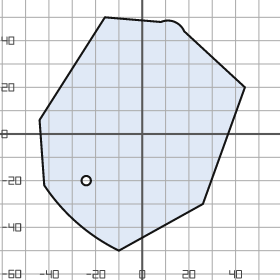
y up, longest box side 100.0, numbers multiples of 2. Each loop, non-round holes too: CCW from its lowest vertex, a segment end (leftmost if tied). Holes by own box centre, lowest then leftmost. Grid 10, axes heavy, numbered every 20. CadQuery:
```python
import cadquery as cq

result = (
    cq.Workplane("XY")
    .moveTo(-10.0, -50.0)
    .lineTo(26.0, -30.0)
    .lineTo(44.0, 20.0)
    .lineTo(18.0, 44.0)
    .threePointArc((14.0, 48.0), (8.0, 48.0))
    .lineTo(-16.0, 50.0)
    .lineTo(-44.0, 6.0)
    .lineTo(-42.0, -22.0)
    .threePointArc((-28.0, -38.0), (-10.0, -50.0))
    .close()
    .moveTo(-24.0, -20.0)
    .circle(2.0)
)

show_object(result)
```